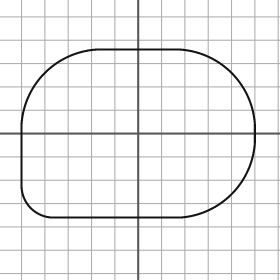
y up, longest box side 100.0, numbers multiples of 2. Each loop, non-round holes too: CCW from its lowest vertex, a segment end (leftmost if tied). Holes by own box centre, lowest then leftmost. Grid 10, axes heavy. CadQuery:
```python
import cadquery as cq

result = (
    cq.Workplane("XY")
    .moveTo(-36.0, -36.0)
    .lineTo(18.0, -36.0)
    .threePointArc((40.0, -26.0), (50.0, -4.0))
    .lineTo(50.0, 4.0)
    .threePointArc((40.0, 26.0), (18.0, 36.0))
    .lineTo(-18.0, 36.0)
    .threePointArc((-40.0, 26.0), (-50.0, 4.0))
    .lineTo(-50.0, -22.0)
    .threePointArc((-46.0, -32.0), (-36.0, -36.0))
    .close()
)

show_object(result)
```